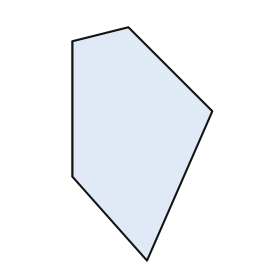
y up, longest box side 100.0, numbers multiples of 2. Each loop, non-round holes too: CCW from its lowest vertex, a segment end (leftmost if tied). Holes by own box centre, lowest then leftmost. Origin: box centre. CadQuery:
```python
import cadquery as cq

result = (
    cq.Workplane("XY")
    .moveTo(2.0, -50.0)
    .lineTo(30.0, 14.0)
    .lineTo(-6.0, 50.0)
    .lineTo(-30.0, 44.0)
    .lineTo(-30.0, -14.0)
    .close()
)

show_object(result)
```